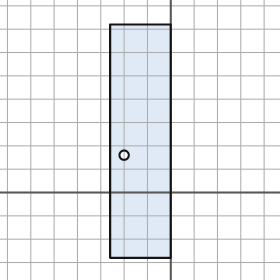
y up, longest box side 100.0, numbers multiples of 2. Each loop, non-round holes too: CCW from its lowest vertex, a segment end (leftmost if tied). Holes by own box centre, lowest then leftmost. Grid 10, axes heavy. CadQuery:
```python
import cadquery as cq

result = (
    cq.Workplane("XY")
    .moveTo(-26.0, -28.0)
    .lineTo(0.0, -28.0)
    .lineTo(0.0, 72.0)
    .lineTo(-26.0, 72.0)
    .close()
    .moveTo(-20.0, 16.0)
    .circle(2.0)
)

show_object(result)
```